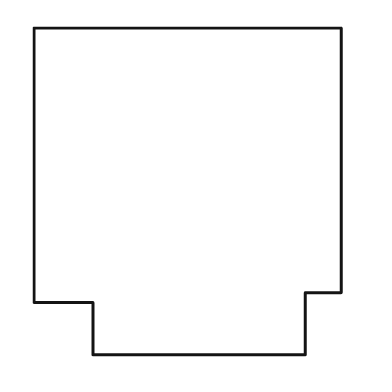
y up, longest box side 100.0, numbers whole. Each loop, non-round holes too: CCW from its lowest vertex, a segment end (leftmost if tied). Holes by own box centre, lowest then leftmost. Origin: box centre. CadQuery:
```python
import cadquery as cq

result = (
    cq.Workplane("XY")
    .moveTo(-29.0, -50.0)
    .lineTo(36.0, -50.0)
    .lineTo(36.0, -31.0)
    .lineTo(47.0, -31.0)
    .lineTo(47.0, 50.0)
    .lineTo(-47.0, 50.0)
    .lineTo(-47.0, -34.0)
    .lineTo(-29.0, -34.0)
    .close()
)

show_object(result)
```